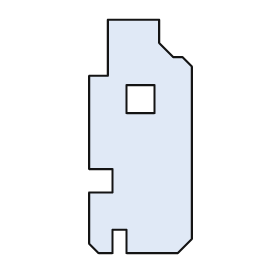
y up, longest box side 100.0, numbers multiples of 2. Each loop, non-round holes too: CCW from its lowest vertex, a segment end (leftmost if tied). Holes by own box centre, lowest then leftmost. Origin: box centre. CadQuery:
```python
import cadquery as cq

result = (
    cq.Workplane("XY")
    .moveTo(-18.0, -50.0)
    .lineTo(-12.0, -50.0)
    .lineTo(-12.0, -40.0)
    .lineTo(-6.0, -40.0)
    .lineTo(-6.0, -50.0)
    .lineTo(16.0, -50.0)
    .lineTo(22.0, -44.0)
    .lineTo(22.0, 30.0)
    .lineTo(18.0, 34.0)
    .lineTo(14.0, 34.0)
    .lineTo(8.0, 40.0)
    .lineTo(8.0, 50.0)
    .lineTo(-14.0, 50.0)
    .lineTo(-14.0, 26.0)
    .lineTo(-22.0, 26.0)
    .lineTo(-22.0, -14.0)
    .lineTo(-12.0, -14.0)
    .lineTo(-12.0, -24.0)
    .lineTo(-22.0, -24.0)
    .lineTo(-22.0, -46.0)
    .close()
    .moveTo(-6.0, 10.0)
    .lineTo(6.0, 10.0)
    .lineTo(6.0, 22.0)
    .lineTo(-6.0, 22.0)
    .close()
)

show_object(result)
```